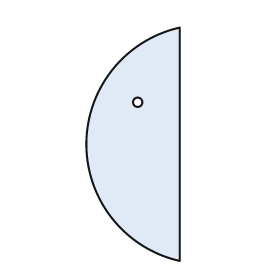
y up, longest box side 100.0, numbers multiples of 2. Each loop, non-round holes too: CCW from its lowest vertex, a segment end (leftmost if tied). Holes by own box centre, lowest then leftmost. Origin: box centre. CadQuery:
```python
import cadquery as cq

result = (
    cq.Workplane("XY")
    .moveTo(20.0, -50.0)
    .lineTo(20.0, 50.0)
    .threePointArc((-20.0, 0.0), (20.0, -50.0))
    .close()
    .moveTo(2.0, 18.0)
    .circle(2.0)
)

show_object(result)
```